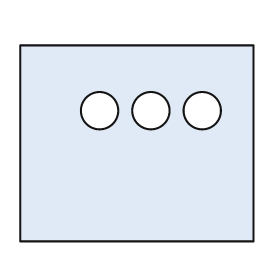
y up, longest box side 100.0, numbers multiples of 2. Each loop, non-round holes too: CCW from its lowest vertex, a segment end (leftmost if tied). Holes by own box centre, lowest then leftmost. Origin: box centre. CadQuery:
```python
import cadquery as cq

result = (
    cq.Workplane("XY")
    .moveTo(-50.0, -42.0)
    .lineTo(50.0, -42.0)
    .lineTo(50.0, 42.0)
    .lineTo(-50.0, 42.0)
    .close()
    .moveTo(-16.0, 14.0)
    .circle(8.0)
    .moveTo(6.0, 14.0)
    .circle(8.0)
    .moveTo(28.0, 14.0)
    .circle(8.0)
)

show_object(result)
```